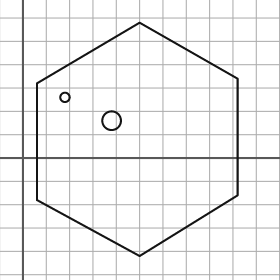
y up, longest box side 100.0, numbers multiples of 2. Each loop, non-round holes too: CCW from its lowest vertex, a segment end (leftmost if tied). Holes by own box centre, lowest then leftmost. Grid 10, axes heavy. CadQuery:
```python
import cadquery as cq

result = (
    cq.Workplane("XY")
    .moveTo(50.0, -42.0)
    .lineTo(92.0, -16.0)
    .lineTo(92.0, 34.0)
    .lineTo(50.0, 58.0)
    .lineTo(6.0, 32.0)
    .lineTo(6.0, -18.0)
    .close()
    .moveTo(38.0, 16.0)
    .circle(4.0)
    .moveTo(18.0, 26.0)
    .circle(2.0)
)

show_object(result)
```